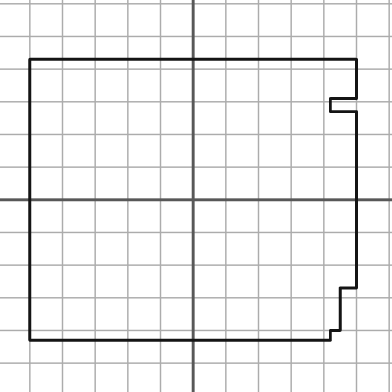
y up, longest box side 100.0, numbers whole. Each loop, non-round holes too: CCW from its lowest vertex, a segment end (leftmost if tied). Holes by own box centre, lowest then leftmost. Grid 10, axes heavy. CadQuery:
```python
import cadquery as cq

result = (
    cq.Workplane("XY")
    .moveTo(-50.0, -43.0)
    .lineTo(42.0, -43.0)
    .lineTo(42.0, -40.0)
    .lineTo(45.0, -40.0)
    .lineTo(45.0, -27.0)
    .lineTo(50.0, -27.0)
    .lineTo(50.0, 27.0)
    .lineTo(42.0, 27.0)
    .lineTo(42.0, 31.0)
    .lineTo(50.0, 31.0)
    .lineTo(50.0, 43.0)
    .lineTo(-50.0, 43.0)
    .close()
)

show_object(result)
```